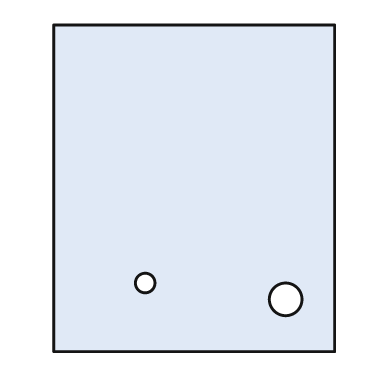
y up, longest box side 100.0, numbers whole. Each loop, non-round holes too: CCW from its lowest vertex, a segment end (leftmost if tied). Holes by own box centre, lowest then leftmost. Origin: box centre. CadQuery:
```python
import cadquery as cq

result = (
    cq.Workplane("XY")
    .moveTo(-43.0, -50.0)
    .lineTo(43.0, -50.0)
    .lineTo(43.0, 50.0)
    .lineTo(-43.0, 50.0)
    .close()
    .moveTo(28.0, -34.0)
    .circle(5.0)
    .moveTo(-15.0, -29.0)
    .circle(3.0)
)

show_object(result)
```